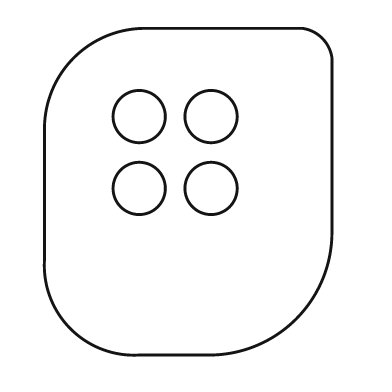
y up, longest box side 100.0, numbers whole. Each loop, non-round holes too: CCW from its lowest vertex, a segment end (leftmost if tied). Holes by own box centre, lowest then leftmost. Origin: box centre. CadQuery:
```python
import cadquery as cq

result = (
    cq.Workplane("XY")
    .moveTo(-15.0, -50.0)
    .lineTo(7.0, -50.0)
    .threePointArc((33.0, -39.0), (44.0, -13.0))
    .lineTo(44.0, 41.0)
    .threePointArc((41.0, 47.0), (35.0, 50.0))
    .lineTo(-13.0, 50.0)
    .threePointArc((-35.0, 41.0), (-44.0, 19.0))
    .lineTo(-44.0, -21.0)
    .threePointArc((-36.0, -42.0), (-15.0, -50.0))
    .close()
    .moveTo(-15.0, 1.0)
    .circle(8.0)
    .moveTo(7.0, 1.0)
    .circle(8.0)
    .moveTo(-15.0, 23.0)
    .circle(8.0)
    .moveTo(7.0, 23.0)
    .circle(8.0)
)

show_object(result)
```